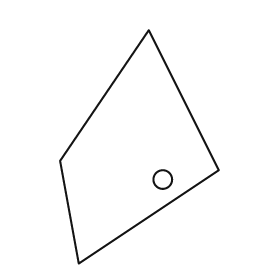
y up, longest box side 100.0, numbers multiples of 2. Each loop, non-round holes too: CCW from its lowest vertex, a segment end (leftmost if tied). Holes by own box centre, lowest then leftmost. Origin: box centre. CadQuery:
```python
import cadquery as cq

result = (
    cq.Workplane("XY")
    .moveTo(-26.0, -50.0)
    .lineTo(34.0, -10.0)
    .lineTo(4.0, 50.0)
    .lineTo(-34.0, -6.0)
    .close()
    .moveTo(10.0, -14.0)
    .circle(4.0)
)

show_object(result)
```